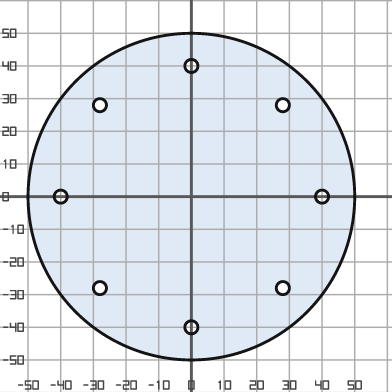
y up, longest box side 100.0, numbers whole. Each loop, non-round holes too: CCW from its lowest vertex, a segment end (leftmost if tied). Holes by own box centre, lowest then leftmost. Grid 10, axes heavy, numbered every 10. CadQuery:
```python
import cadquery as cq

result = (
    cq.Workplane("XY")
    .moveTo(0.0, 0.0)
    .circle(50.0)
    .moveTo(0.0, -40.0)
    .circle(2.0)
    .moveTo(-28.0, -28.0)
    .circle(2.0)
    .moveTo(28.0, -28.0)
    .circle(2.0)
    .moveTo(-40.0, 0.0)
    .circle(2.0)
    .moveTo(40.0, 0.0)
    .circle(2.0)
    .moveTo(-28.0, 28.0)
    .circle(2.0)
    .moveTo(28.0, 28.0)
    .circle(2.0)
    .moveTo(0.0, 40.0)
    .circle(2.0)
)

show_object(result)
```